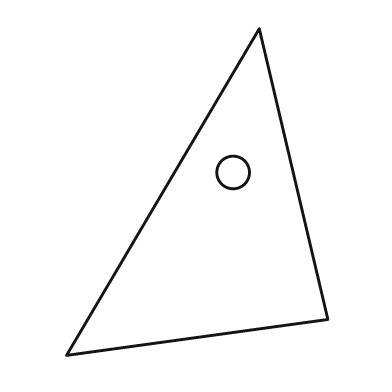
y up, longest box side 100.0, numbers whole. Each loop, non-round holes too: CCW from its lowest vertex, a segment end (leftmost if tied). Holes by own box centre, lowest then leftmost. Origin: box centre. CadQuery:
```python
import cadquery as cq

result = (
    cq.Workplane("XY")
    .moveTo(-40.0, -50.0)
    .lineTo(40.0, -39.0)
    .lineTo(19.0, 50.0)
    .close()
    .moveTo(11.0, 6.0)
    .circle(5.0)
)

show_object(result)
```